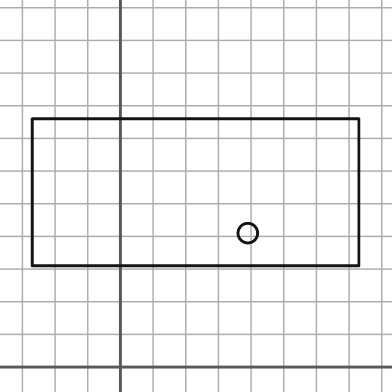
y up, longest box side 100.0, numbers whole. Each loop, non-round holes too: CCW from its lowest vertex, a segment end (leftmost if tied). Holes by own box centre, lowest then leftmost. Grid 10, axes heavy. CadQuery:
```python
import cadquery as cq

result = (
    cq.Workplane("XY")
    .moveTo(-27.0, 31.0)
    .lineTo(73.0, 31.0)
    .lineTo(73.0, 76.0)
    .lineTo(-27.0, 76.0)
    .close()
    .moveTo(39.0, 41.0)
    .circle(3.0)
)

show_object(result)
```